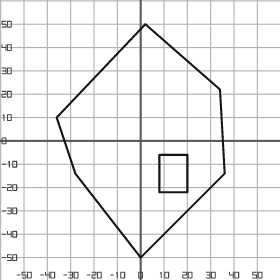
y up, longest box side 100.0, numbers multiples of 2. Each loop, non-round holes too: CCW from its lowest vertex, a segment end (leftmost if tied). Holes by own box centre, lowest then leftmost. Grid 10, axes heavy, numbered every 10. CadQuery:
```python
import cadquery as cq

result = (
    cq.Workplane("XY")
    .moveTo(0.0, -50.0)
    .lineTo(36.0, -14.0)
    .lineTo(34.0, 22.0)
    .lineTo(2.0, 50.0)
    .lineTo(-36.0, 10.0)
    .lineTo(-28.0, -14.0)
    .close()
    .moveTo(8.0, -22.0)
    .lineTo(20.0, -22.0)
    .lineTo(20.0, -6.0)
    .lineTo(8.0, -6.0)
    .close()
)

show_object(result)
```